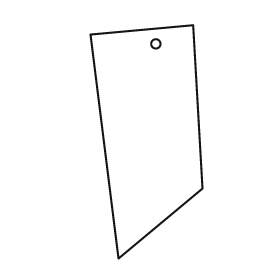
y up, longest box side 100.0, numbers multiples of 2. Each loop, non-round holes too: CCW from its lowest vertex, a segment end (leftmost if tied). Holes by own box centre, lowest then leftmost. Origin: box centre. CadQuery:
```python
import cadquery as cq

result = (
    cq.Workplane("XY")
    .moveTo(-12.0, -50.0)
    .lineTo(24.0, -20.0)
    .lineTo(20.0, 50.0)
    .lineTo(-24.0, 46.0)
    .close()
    .moveTo(4.0, 42.0)
    .circle(2.0)
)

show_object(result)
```